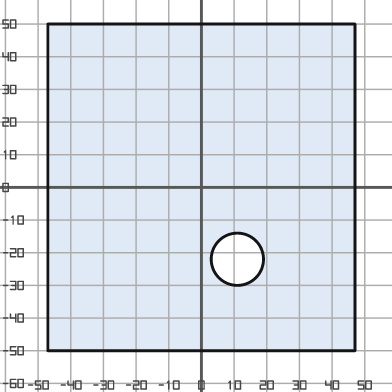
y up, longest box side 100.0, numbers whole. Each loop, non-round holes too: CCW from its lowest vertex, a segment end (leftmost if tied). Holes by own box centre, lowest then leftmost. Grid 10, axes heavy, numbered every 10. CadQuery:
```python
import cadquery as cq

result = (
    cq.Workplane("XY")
    .moveTo(-47.0, -50.0)
    .lineTo(47.0, -50.0)
    .lineTo(47.0, 50.0)
    .lineTo(-47.0, 50.0)
    .close()
    .moveTo(11.0, -22.0)
    .circle(8.0)
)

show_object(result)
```